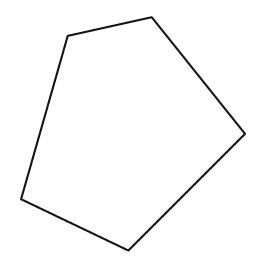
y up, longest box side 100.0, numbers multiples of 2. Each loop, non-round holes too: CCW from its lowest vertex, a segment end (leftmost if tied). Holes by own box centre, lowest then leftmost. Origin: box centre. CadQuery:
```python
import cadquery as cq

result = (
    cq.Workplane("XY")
    .moveTo(-2.0, -50.0)
    .lineTo(48.0, 0.0)
    .lineTo(8.0, 50.0)
    .lineTo(-28.0, 42.0)
    .lineTo(-48.0, -28.0)
    .close()
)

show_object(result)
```